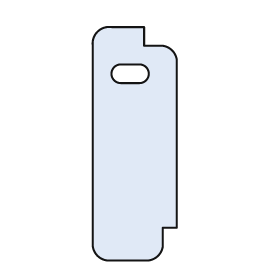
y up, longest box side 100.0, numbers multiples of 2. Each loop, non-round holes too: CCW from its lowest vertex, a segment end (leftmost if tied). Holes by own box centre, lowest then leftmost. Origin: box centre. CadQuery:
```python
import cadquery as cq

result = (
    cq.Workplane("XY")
    .moveTo(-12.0, -50.0)
    .lineTo(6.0, -50.0)
    .threePointArc((10.0, -48.0), (12.0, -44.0))
    .lineTo(12.0, -36.0)
    .lineTo(18.0, -36.0)
    .lineTo(18.0, 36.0)
    .threePointArc((16.0, 40.0), (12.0, 42.0))
    .lineTo(4.0, 42.0)
    .lineTo(4.0, 50.0)
    .lineTo(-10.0, 50.0)
    .threePointArc((-16.0, 48.0), (-18.0, 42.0))
    .lineTo(-18.0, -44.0)
    .threePointArc((-16.0, -48.0), (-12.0, -50.0))
    .close()
    .moveTo(-6.0, 26.0)
    .lineTo(2.0, 26.0)
    .threePointArc((6.0, 30.0), (2.0, 34.0))
    .lineTo(-6.0, 34.0)
    .threePointArc((-10.0, 30.0), (-6.0, 26.0))
    .close()
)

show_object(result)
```